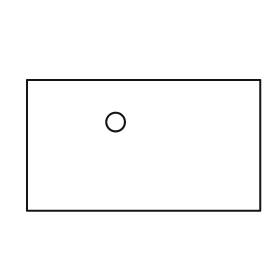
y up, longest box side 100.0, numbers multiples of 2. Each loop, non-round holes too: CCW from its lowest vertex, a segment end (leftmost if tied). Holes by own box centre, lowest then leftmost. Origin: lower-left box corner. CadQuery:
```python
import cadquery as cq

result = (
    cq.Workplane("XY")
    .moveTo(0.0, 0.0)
    .lineTo(100.0, 0.0)
    .lineTo(100.0, 56.0)
    .lineTo(0.0, 56.0)
    .close()
    .moveTo(38.0, 38.0)
    .circle(4.0)
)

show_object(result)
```